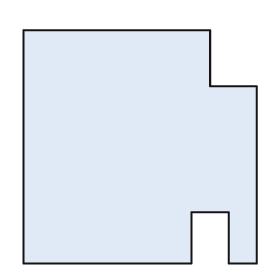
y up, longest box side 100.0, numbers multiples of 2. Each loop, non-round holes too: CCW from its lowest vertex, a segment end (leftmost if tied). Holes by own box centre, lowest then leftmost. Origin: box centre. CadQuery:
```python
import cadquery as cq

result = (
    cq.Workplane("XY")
    .moveTo(-50.0, -50.0)
    .lineTo(22.0, -50.0)
    .lineTo(22.0, -28.0)
    .lineTo(38.0, -28.0)
    .lineTo(38.0, -50.0)
    .lineTo(50.0, -50.0)
    .lineTo(50.0, 26.0)
    .lineTo(30.0, 26.0)
    .lineTo(30.0, 50.0)
    .lineTo(-50.0, 50.0)
    .close()
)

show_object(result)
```